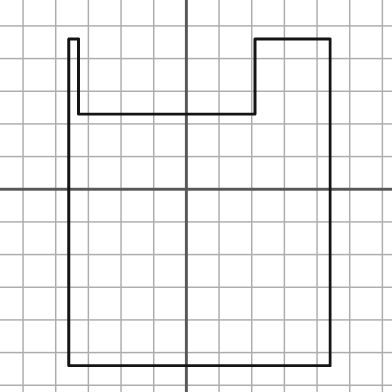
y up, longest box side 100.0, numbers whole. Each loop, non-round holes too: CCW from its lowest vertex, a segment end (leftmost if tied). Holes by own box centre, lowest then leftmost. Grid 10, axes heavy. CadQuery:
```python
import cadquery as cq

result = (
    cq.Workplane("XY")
    .moveTo(-36.0, -54.0)
    .lineTo(44.0, -54.0)
    .lineTo(44.0, 46.0)
    .lineTo(21.0, 46.0)
    .lineTo(21.0, 23.0)
    .lineTo(-33.0, 23.0)
    .lineTo(-33.0, 46.0)
    .lineTo(-36.0, 46.0)
    .close()
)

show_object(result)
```